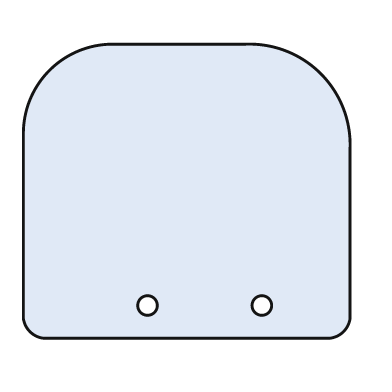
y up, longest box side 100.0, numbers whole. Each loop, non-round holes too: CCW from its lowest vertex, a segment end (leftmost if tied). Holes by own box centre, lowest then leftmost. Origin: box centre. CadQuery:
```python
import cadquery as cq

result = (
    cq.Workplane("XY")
    .moveTo(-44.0, -45.0)
    .lineTo(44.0, -45.0)
    .threePointArc((48.0, -43.0), (50.0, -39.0))
    .lineTo(50.0, 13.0)
    .threePointArc((41.0, 36.0), (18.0, 45.0))
    .lineTo(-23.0, 45.0)
    .threePointArc((-42.0, 37.0), (-50.0, 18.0))
    .lineTo(-50.0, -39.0)
    .threePointArc((-48.0, -43.0), (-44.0, -45.0))
    .close()
    .moveTo(-12.0, -35.0)
    .circle(3.0)
    .moveTo(23.0, -35.0)
    .circle(3.0)
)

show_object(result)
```